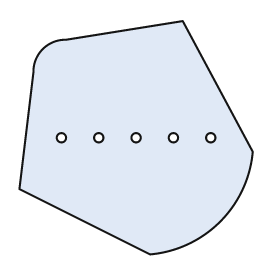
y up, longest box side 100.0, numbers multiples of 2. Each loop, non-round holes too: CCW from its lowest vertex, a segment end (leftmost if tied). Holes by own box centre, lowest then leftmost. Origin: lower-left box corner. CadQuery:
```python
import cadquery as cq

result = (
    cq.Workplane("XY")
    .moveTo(56.0, 0.0)
    .threePointArc((86.0, 14.0), (100.0, 44.0))
    .lineTo(70.0, 100.0)
    .lineTo(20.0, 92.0)
    .threePointArc((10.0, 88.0), (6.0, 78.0))
    .lineTo(0.0, 28.0)
    .close()
    .moveTo(18.0, 50.0)
    .circle(2.0)
    .moveTo(34.0, 50.0)
    .circle(2.0)
    .moveTo(50.0, 50.0)
    .circle(2.0)
    .moveTo(66.0, 50.0)
    .circle(2.0)
    .moveTo(82.0, 50.0)
    .circle(2.0)
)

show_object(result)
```